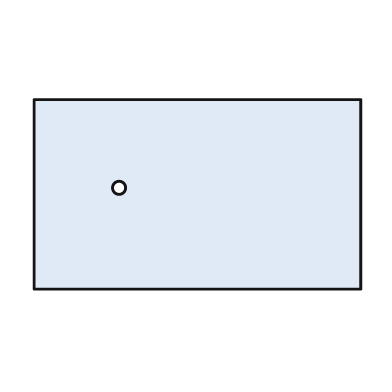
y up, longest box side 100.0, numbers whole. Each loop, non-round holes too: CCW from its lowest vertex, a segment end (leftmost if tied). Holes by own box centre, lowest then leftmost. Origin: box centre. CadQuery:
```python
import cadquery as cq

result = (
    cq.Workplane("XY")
    .moveTo(-50.0, -29.0)
    .lineTo(50.0, -29.0)
    .lineTo(50.0, 29.0)
    .lineTo(-50.0, 29.0)
    .close()
    .moveTo(-24.0, 2.0)
    .circle(2.0)
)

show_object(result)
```